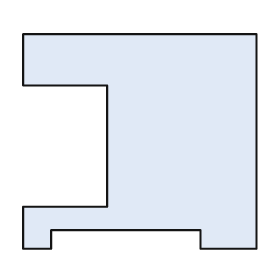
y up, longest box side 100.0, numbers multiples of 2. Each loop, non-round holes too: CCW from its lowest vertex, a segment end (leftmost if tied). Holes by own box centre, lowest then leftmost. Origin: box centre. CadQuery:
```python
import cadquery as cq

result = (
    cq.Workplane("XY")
    .moveTo(-50.0, -46.0)
    .lineTo(-38.0, -46.0)
    .lineTo(-38.0, -38.0)
    .lineTo(26.0, -38.0)
    .lineTo(26.0, -46.0)
    .lineTo(50.0, -46.0)
    .lineTo(50.0, 46.0)
    .lineTo(-50.0, 46.0)
    .lineTo(-50.0, 24.0)
    .lineTo(-14.0, 24.0)
    .lineTo(-14.0, -28.0)
    .lineTo(-50.0, -28.0)
    .close()
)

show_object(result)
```